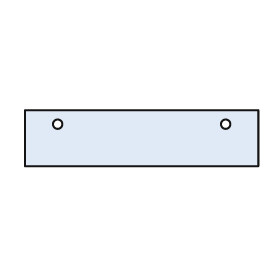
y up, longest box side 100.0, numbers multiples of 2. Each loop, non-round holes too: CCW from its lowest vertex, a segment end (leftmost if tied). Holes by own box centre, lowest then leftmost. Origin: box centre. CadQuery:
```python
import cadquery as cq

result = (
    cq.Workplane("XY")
    .moveTo(-50.0, -12.0)
    .lineTo(50.0, -12.0)
    .lineTo(50.0, 12.0)
    .lineTo(-50.0, 12.0)
    .close()
    .moveTo(-36.0, 6.0)
    .circle(2.0)
    .moveTo(36.0, 6.0)
    .circle(2.0)
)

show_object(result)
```